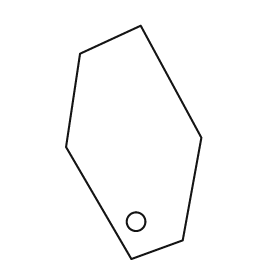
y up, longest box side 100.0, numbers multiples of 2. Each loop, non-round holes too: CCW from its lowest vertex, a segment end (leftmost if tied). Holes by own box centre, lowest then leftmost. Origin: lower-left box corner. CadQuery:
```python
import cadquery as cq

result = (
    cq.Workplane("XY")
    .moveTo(28.0, 0.0)
    .lineTo(50.0, 8.0)
    .lineTo(58.0, 52.0)
    .lineTo(32.0, 100.0)
    .lineTo(6.0, 88.0)
    .lineTo(0.0, 48.0)
    .close()
    .moveTo(30.0, 16.0)
    .circle(4.0)
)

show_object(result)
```